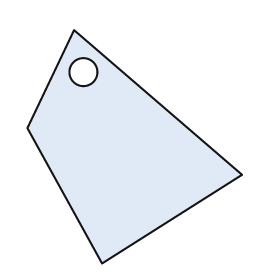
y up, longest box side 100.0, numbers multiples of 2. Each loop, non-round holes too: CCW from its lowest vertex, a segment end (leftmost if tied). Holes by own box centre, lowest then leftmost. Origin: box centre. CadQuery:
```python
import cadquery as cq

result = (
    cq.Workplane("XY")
    .moveTo(-14.0, -50.0)
    .lineTo(46.0, -12.0)
    .lineTo(-26.0, 50.0)
    .lineTo(-46.0, 8.0)
    .close()
    .moveTo(-22.0, 32.0)
    .circle(6.0)
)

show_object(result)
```